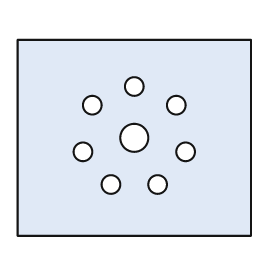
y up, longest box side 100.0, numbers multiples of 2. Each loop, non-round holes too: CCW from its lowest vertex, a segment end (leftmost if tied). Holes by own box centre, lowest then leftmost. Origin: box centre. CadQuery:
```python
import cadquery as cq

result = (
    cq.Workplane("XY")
    .moveTo(-50.0, -42.0)
    .lineTo(50.0, -42.0)
    .lineTo(50.0, 42.0)
    .lineTo(-50.0, 42.0)
    .close()
    .moveTo(-10.0, -20.0)
    .circle(4.0)
    .moveTo(10.0, -20.0)
    .circle(4.0)
    .moveTo(-22.0, -6.0)
    .circle(4.0)
    .moveTo(22.0, -6.0)
    .circle(4.0)
    .moveTo(0.0, 0.0)
    .circle(6.0)
    .moveTo(-18.0, 14.0)
    .circle(4.0)
    .moveTo(18.0, 14.0)
    .circle(4.0)
    .moveTo(0.0, 22.0)
    .circle(4.0)
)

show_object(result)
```